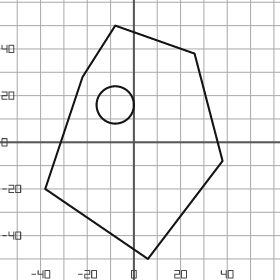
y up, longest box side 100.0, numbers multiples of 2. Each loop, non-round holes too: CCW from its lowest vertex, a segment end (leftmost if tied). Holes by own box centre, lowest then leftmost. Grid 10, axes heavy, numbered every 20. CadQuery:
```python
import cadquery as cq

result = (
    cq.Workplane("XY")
    .moveTo(6.0, -50.0)
    .lineTo(38.0, -8.0)
    .lineTo(26.0, 38.0)
    .lineTo(-8.0, 50.0)
    .lineTo(-22.0, 28.0)
    .lineTo(-38.0, -20.0)
    .close()
    .moveTo(-8.0, 16.0)
    .circle(8.0)
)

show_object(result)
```